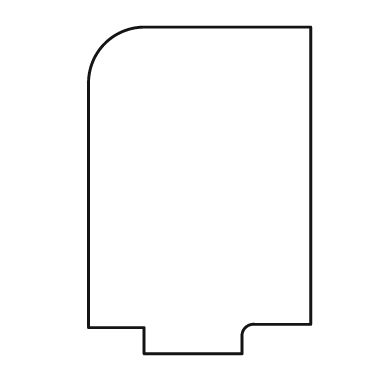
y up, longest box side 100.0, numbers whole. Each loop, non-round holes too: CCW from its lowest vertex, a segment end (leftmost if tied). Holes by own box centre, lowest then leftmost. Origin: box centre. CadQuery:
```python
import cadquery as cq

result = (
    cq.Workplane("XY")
    .moveTo(-17.0, -50.0)
    .lineTo(13.0, -50.0)
    .lineTo(13.0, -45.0)
    .threePointArc((14.0, -42.0), (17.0, -41.0))
    .lineTo(34.0, -41.0)
    .lineTo(34.0, 50.0)
    .lineTo(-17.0, 50.0)
    .threePointArc((-29.0, 45.0), (-34.0, 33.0))
    .lineTo(-34.0, -42.0)
    .lineTo(-17.0, -42.0)
    .close()
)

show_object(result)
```